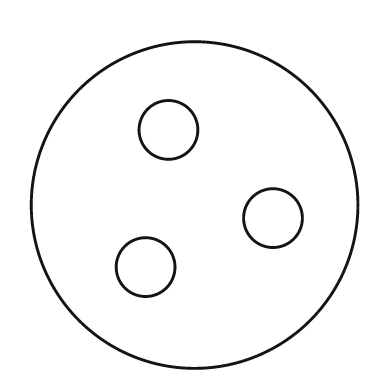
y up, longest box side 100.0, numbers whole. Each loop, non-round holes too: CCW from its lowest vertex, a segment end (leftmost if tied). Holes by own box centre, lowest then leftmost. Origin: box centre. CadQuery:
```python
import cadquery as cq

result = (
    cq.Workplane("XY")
    .moveTo(0.0, 0.0)
    .circle(50.0)
    .moveTo(-15.0, -19.0)
    .circle(9.0)
    .moveTo(24.0, -4.0)
    .circle(9.0)
    .moveTo(-8.0, 23.0)
    .circle(9.0)
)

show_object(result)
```